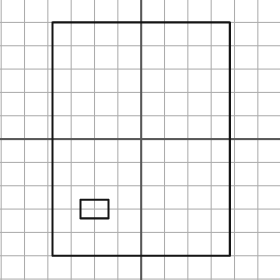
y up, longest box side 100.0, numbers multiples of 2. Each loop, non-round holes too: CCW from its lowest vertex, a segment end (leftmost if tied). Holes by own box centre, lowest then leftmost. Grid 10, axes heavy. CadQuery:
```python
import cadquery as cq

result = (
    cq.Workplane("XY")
    .moveTo(-38.0, -50.0)
    .lineTo(38.0, -50.0)
    .lineTo(38.0, 50.0)
    .lineTo(-38.0, 50.0)
    .close()
    .moveTo(-26.0, -34.0)
    .lineTo(-14.0, -34.0)
    .lineTo(-14.0, -26.0)
    .lineTo(-26.0, -26.0)
    .close()
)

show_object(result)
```